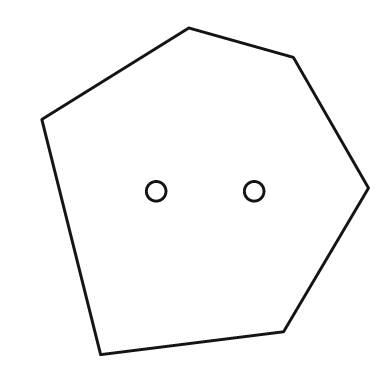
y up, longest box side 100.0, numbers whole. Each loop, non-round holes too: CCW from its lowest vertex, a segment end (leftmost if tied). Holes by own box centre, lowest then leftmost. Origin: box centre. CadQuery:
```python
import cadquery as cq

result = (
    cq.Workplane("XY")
    .moveTo(-32.0, -50.0)
    .lineTo(24.0, -43.0)
    .lineTo(50.0, 1.0)
    .lineTo(27.0, 41.0)
    .lineTo(-5.0, 50.0)
    .lineTo(-50.0, 22.0)
    .close()
    .moveTo(-15.0, 0.0)
    .circle(3.0)
    .moveTo(15.0, 0.0)
    .circle(3.0)
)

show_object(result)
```